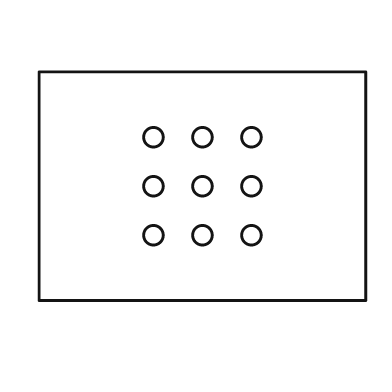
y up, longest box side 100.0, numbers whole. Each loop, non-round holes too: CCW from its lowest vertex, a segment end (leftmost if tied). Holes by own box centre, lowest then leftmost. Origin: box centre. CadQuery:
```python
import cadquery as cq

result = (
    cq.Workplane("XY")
    .moveTo(-50.0, -35.0)
    .lineTo(50.0, -35.0)
    .lineTo(50.0, 35.0)
    .lineTo(-50.0, 35.0)
    .close()
    .moveTo(-15.0, -15.0)
    .circle(3.0)
    .moveTo(0.0, -15.0)
    .circle(3.0)
    .moveTo(15.0, -15.0)
    .circle(3.0)
    .moveTo(-15.0, 0.0)
    .circle(3.0)
    .moveTo(0.0, 0.0)
    .circle(3.0)
    .moveTo(15.0, 0.0)
    .circle(3.0)
    .moveTo(-15.0, 15.0)
    .circle(3.0)
    .moveTo(0.0, 15.0)
    .circle(3.0)
    .moveTo(15.0, 15.0)
    .circle(3.0)
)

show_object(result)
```